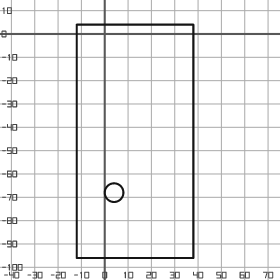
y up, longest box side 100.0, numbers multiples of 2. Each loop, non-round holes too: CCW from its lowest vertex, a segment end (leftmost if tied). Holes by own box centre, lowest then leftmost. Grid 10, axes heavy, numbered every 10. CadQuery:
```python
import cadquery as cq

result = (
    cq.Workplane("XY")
    .moveTo(-12.0, -96.0)
    .lineTo(38.0, -96.0)
    .lineTo(38.0, 4.0)
    .lineTo(-12.0, 4.0)
    .close()
    .moveTo(4.0, -68.0)
    .circle(4.0)
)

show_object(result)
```